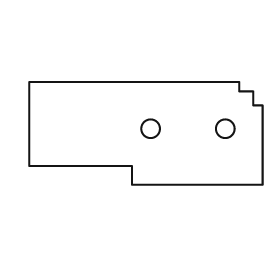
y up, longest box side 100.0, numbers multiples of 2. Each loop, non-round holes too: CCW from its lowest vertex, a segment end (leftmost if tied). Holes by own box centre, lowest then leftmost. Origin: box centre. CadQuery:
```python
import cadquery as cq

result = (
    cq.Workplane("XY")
    .moveTo(-6.0, -22.0)
    .lineTo(50.0, -22.0)
    .lineTo(50.0, 12.0)
    .lineTo(46.0, 12.0)
    .lineTo(46.0, 18.0)
    .lineTo(40.0, 18.0)
    .lineTo(40.0, 22.0)
    .lineTo(-50.0, 22.0)
    .lineTo(-50.0, -14.0)
    .lineTo(-6.0, -14.0)
    .close()
    .moveTo(2.0, 2.0)
    .circle(4.0)
    .moveTo(34.0, 2.0)
    .circle(4.0)
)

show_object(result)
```